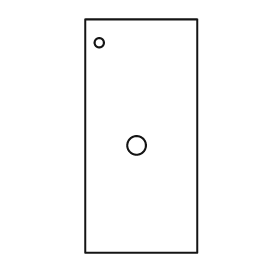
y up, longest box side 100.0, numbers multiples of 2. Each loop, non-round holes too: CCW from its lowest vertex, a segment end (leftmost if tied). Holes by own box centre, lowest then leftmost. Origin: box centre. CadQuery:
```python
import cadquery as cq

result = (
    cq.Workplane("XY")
    .moveTo(-24.0, -50.0)
    .lineTo(24.0, -50.0)
    .lineTo(24.0, 50.0)
    .lineTo(-24.0, 50.0)
    .close()
    .moveTo(-2.0, -4.0)
    .circle(4.0)
    .moveTo(-18.0, 40.0)
    .circle(2.0)
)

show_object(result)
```